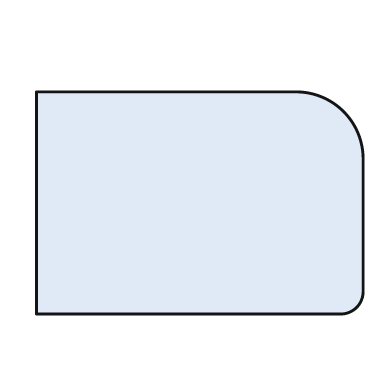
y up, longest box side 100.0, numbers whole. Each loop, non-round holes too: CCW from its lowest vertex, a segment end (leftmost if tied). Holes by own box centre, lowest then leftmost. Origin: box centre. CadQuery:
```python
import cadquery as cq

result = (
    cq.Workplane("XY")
    .moveTo(-50.0, -34.0)
    .lineTo(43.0, -34.0)
    .threePointArc((48.0, -32.0), (50.0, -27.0))
    .lineTo(50.0, 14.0)
    .threePointArc((44.0, 28.0), (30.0, 34.0))
    .lineTo(-50.0, 34.0)
    .close()
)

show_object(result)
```